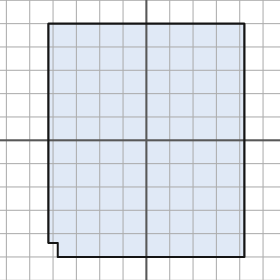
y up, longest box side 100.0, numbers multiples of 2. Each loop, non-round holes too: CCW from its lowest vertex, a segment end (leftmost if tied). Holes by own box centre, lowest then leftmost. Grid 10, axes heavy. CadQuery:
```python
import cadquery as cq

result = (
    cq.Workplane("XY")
    .moveTo(-38.0, -50.0)
    .lineTo(42.0, -50.0)
    .lineTo(42.0, 50.0)
    .lineTo(-42.0, 50.0)
    .lineTo(-42.0, -44.0)
    .lineTo(-38.0, -44.0)
    .close()
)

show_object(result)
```